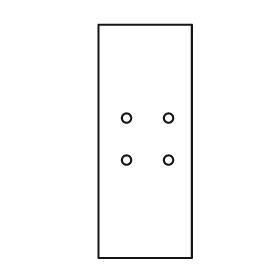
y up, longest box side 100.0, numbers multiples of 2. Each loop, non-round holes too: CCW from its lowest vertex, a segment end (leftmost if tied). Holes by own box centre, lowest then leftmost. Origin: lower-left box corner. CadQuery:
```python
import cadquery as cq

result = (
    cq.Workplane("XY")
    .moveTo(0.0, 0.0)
    .lineTo(40.0, 0.0)
    .lineTo(40.0, 100.0)
    .lineTo(0.0, 100.0)
    .close()
    .moveTo(12.0, 42.0)
    .circle(2.0)
    .moveTo(30.0, 42.0)
    .circle(2.0)
    .moveTo(12.0, 60.0)
    .circle(2.0)
    .moveTo(30.0, 60.0)
    .circle(2.0)
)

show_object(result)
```